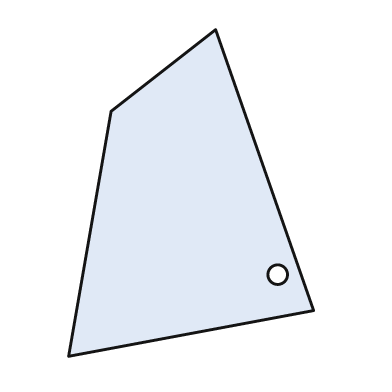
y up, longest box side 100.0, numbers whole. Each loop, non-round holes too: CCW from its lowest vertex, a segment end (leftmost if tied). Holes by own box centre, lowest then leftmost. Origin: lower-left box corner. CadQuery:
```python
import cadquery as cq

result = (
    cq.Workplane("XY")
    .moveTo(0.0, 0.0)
    .lineTo(75.0, 14.0)
    .lineTo(45.0, 100.0)
    .lineTo(13.0, 75.0)
    .close()
    .moveTo(64.0, 25.0)
    .circle(3.0)
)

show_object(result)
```